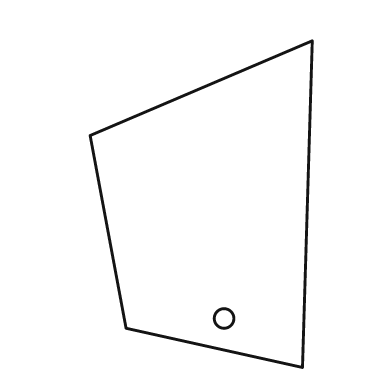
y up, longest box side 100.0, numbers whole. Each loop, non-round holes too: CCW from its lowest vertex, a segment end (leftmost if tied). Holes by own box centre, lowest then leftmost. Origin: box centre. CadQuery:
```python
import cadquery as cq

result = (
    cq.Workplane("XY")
    .moveTo(31.0, -50.0)
    .lineTo(34.0, 50.0)
    .lineTo(-34.0, 21.0)
    .lineTo(-23.0, -38.0)
    .close()
    .moveTo(7.0, -35.0)
    .circle(3.0)
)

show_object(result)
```